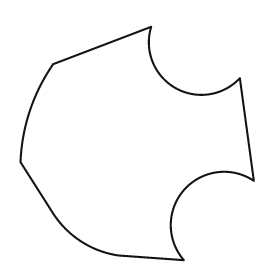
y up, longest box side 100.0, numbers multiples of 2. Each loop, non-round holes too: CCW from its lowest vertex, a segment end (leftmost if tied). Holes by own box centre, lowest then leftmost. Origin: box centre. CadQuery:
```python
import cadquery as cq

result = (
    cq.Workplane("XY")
    .moveTo(20.0, -50.0)
    .threePointArc((20.0, -20.0), (50.0, -16.0))
    .lineTo(44.0, 28.0)
    .threePointArc((16.0, 24.0), (6.0, 50.0))
    .lineTo(-36.0, 34.0)
    .threePointArc((-46.0, 14.0), (-50.0, -8.0))
    .lineTo(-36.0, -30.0)
    .threePointArc((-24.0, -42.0), (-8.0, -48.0))
    .close()
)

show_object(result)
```